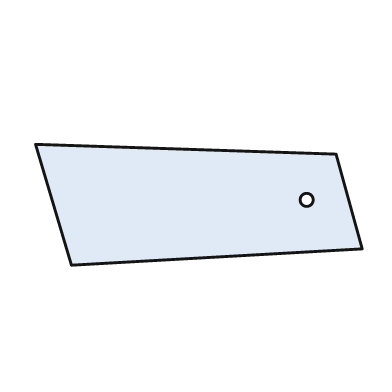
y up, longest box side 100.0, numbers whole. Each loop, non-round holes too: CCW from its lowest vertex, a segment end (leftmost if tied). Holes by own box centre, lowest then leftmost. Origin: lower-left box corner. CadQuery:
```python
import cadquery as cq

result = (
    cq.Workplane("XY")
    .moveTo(11.0, 0.0)
    .lineTo(100.0, 5.0)
    .lineTo(92.0, 34.0)
    .lineTo(0.0, 37.0)
    .close()
    .moveTo(83.0, 20.0)
    .circle(2.0)
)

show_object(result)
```